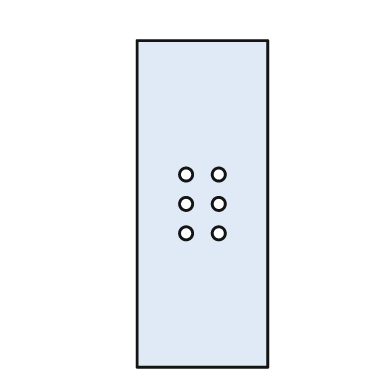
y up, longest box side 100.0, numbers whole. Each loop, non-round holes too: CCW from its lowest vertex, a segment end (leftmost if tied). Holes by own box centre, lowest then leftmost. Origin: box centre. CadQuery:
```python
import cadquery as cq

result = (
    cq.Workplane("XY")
    .moveTo(-20.0, -50.0)
    .lineTo(20.0, -50.0)
    .lineTo(20.0, 50.0)
    .lineTo(-20.0, 50.0)
    .close()
    .moveTo(-5.0, -9.0)
    .circle(2.0)
    .moveTo(5.0, -9.0)
    .circle(2.0)
    .moveTo(-5.0, 0.0)
    .circle(2.0)
    .moveTo(5.0, 0.0)
    .circle(2.0)
    .moveTo(-5.0, 9.0)
    .circle(2.0)
    .moveTo(5.0, 9.0)
    .circle(2.0)
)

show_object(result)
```